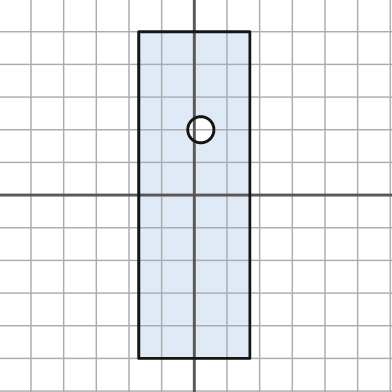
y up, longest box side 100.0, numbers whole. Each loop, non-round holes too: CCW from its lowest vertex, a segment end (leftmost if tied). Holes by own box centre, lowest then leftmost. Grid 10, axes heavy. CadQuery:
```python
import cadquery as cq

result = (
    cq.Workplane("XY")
    .moveTo(-17.0, -50.0)
    .lineTo(17.0, -50.0)
    .lineTo(17.0, 50.0)
    .lineTo(-17.0, 50.0)
    .close()
    .moveTo(2.0, 20.0)
    .circle(4.0)
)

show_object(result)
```